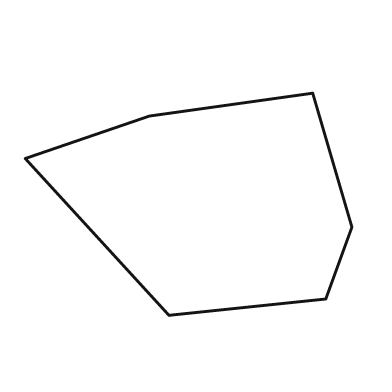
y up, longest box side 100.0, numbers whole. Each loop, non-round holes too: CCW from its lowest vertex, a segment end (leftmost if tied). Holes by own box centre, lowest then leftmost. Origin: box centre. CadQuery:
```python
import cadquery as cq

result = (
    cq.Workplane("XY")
    .moveTo(-6.0, -34.0)
    .lineTo(42.0, -29.0)
    .lineTo(50.0, -7.0)
    .lineTo(38.0, 34.0)
    .lineTo(-12.0, 27.0)
    .lineTo(-50.0, 14.0)
    .close()
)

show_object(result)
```